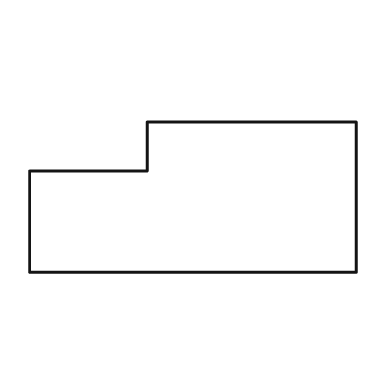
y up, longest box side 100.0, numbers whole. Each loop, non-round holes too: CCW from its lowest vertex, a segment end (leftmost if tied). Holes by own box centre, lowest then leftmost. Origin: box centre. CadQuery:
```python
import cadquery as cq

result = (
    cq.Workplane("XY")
    .moveTo(-50.0, -23.0)
    .lineTo(50.0, -23.0)
    .lineTo(50.0, 23.0)
    .lineTo(-14.0, 23.0)
    .lineTo(-14.0, 8.0)
    .lineTo(-50.0, 8.0)
    .close()
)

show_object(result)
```